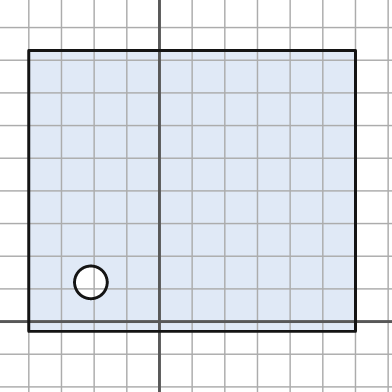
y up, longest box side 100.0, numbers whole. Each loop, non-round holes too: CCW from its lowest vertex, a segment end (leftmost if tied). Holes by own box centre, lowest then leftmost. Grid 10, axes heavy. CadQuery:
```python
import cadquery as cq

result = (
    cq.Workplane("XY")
    .moveTo(-40.0, -3.0)
    .lineTo(60.0, -3.0)
    .lineTo(60.0, 83.0)
    .lineTo(-40.0, 83.0)
    .close()
    .moveTo(-21.0, 12.0)
    .circle(5.0)
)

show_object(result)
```